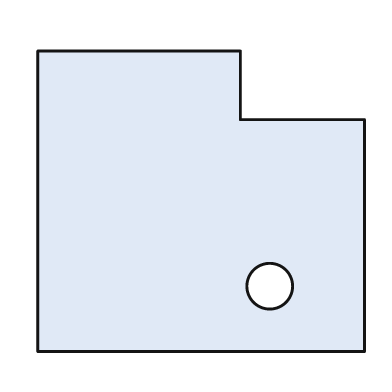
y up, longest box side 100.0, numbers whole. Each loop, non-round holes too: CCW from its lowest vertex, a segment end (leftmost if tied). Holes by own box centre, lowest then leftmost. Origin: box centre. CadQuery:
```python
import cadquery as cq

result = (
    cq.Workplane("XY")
    .moveTo(-50.0, -46.0)
    .lineTo(50.0, -46.0)
    .lineTo(50.0, 25.0)
    .lineTo(12.0, 25.0)
    .lineTo(12.0, 46.0)
    .lineTo(-50.0, 46.0)
    .close()
    .moveTo(21.0, -26.0)
    .circle(7.0)
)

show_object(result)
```